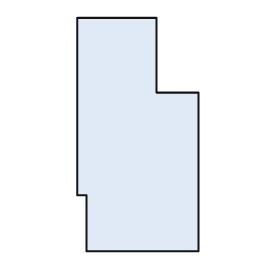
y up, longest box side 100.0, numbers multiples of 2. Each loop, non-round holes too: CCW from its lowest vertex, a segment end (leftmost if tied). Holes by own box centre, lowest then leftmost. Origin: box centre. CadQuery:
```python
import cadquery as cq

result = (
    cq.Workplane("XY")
    .moveTo(-22.0, -50.0)
    .lineTo(26.0, -50.0)
    .lineTo(26.0, 18.0)
    .lineTo(8.0, 18.0)
    .lineTo(8.0, 50.0)
    .lineTo(-26.0, 50.0)
    .lineTo(-26.0, -26.0)
    .lineTo(-22.0, -26.0)
    .close()
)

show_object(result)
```